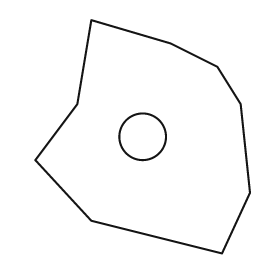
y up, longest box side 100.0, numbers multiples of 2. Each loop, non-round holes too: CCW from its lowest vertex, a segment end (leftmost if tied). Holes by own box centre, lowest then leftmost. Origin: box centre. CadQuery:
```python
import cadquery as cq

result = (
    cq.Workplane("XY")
    .moveTo(34.0, -50.0)
    .lineTo(46.0, -24.0)
    .lineTo(42.0, 14.0)
    .lineTo(32.0, 30.0)
    .lineTo(12.0, 40.0)
    .lineTo(-22.0, 50.0)
    .lineTo(-28.0, 14.0)
    .lineTo(-46.0, -10.0)
    .lineTo(-22.0, -36.0)
    .close()
    .moveTo(0.0, 0.0)
    .circle(10.0)
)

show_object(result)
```